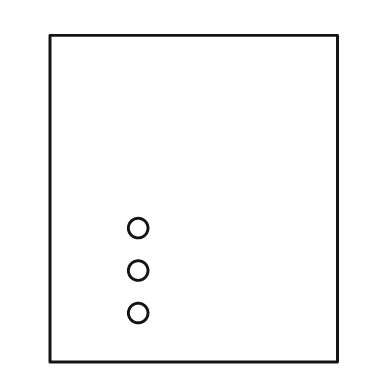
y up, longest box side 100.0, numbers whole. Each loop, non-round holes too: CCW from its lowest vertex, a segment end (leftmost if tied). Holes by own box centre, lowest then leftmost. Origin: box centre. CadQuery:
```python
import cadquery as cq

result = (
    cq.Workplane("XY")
    .moveTo(-44.0, -50.0)
    .lineTo(44.0, -50.0)
    .lineTo(44.0, 50.0)
    .lineTo(-44.0, 50.0)
    .close()
    .moveTo(-17.0, -35.0)
    .circle(3.0)
    .moveTo(-17.0, -22.0)
    .circle(3.0)
    .moveTo(-17.0, -9.0)
    .circle(3.0)
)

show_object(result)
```